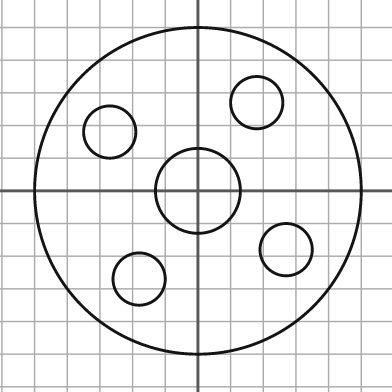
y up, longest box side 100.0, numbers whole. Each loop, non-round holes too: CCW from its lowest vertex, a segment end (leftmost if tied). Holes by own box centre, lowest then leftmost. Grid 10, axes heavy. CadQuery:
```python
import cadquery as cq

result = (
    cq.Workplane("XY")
    .moveTo(0.0, 0.0)
    .circle(50.0)
    .moveTo(-18.0, -27.0)
    .circle(8.0)
    .moveTo(27.0, -18.0)
    .circle(8.0)
    .moveTo(0.0, 0.0)
    .circle(13.0)
    .moveTo(-27.0, 18.0)
    .circle(8.0)
    .moveTo(18.0, 27.0)
    .circle(8.0)
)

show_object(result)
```